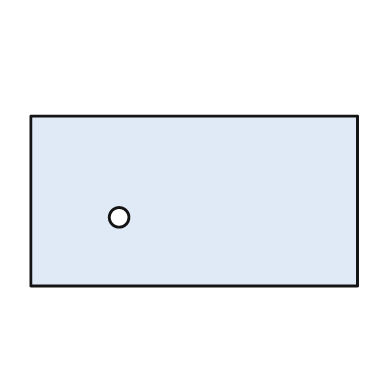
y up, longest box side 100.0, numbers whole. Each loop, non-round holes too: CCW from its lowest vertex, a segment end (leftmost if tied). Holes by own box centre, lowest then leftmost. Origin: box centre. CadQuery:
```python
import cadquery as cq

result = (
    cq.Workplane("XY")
    .moveTo(-50.0, -26.0)
    .lineTo(50.0, -26.0)
    .lineTo(50.0, 26.0)
    .lineTo(-50.0, 26.0)
    .close()
    .moveTo(-23.0, -5.0)
    .circle(3.0)
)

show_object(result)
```